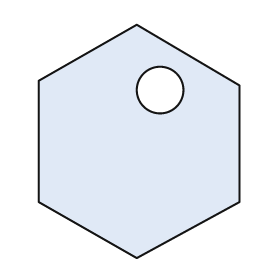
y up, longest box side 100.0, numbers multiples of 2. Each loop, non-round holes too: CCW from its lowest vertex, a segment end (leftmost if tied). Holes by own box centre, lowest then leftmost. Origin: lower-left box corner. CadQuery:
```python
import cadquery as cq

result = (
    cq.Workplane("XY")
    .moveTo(42.0, 0.0)
    .lineTo(86.0, 24.0)
    .lineTo(86.0, 74.0)
    .lineTo(42.0, 100.0)
    .lineTo(0.0, 76.0)
    .lineTo(0.0, 24.0)
    .close()
    .moveTo(52.0, 72.0)
    .circle(10.0)
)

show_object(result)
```